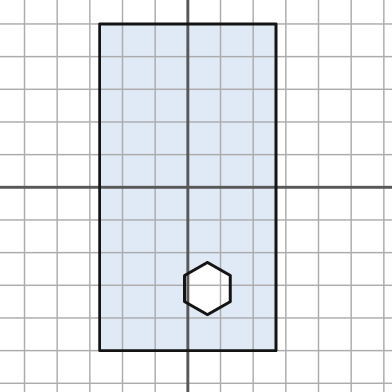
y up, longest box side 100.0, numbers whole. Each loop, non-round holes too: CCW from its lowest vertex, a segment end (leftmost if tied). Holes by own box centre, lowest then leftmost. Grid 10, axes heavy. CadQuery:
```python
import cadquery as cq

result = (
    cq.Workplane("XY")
    .moveTo(-27.0, -50.0)
    .lineTo(27.0, -50.0)
    .lineTo(27.0, 50.0)
    .lineTo(-27.0, 50.0)
    .close()
    .moveTo(6.0, -39.0)
    .lineTo(13.0, -35.0)
    .lineTo(13.0, -27.0)
    .lineTo(6.0, -23.0)
    .lineTo(-1.0, -27.0)
    .lineTo(-1.0, -35.0)
    .close()
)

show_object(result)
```